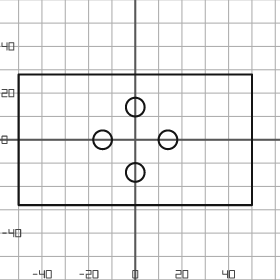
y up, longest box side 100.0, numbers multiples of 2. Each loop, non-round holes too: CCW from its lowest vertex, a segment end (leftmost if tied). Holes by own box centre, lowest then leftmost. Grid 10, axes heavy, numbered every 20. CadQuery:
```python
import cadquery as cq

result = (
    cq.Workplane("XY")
    .moveTo(-50.0, -28.0)
    .lineTo(50.0, -28.0)
    .lineTo(50.0, 28.0)
    .lineTo(-50.0, 28.0)
    .close()
    .moveTo(0.0, -14.0)
    .circle(4.0)
    .moveTo(-14.0, 0.0)
    .circle(4.0)
    .moveTo(14.0, 0.0)
    .circle(4.0)
    .moveTo(0.0, 14.0)
    .circle(4.0)
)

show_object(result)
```